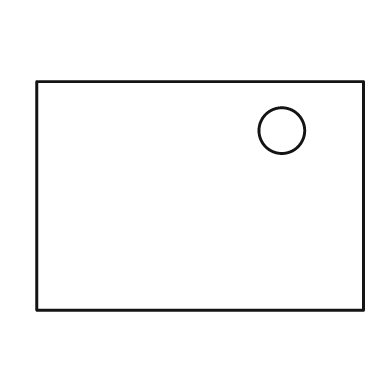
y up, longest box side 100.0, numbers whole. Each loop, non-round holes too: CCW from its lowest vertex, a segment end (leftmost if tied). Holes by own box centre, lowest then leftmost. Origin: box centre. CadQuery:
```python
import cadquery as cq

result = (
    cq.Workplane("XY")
    .moveTo(-50.0, -35.0)
    .lineTo(50.0, -35.0)
    .lineTo(50.0, 35.0)
    .lineTo(-50.0, 35.0)
    .close()
    .moveTo(25.0, 20.0)
    .circle(7.0)
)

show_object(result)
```